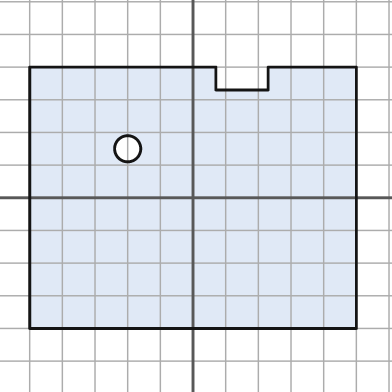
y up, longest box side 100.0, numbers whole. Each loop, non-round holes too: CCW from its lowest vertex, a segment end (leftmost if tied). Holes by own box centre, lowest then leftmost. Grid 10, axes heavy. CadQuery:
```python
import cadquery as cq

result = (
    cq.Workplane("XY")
    .moveTo(-50.0, -40.0)
    .lineTo(50.0, -40.0)
    .lineTo(50.0, 40.0)
    .lineTo(23.0, 40.0)
    .lineTo(23.0, 33.0)
    .lineTo(7.0, 33.0)
    .lineTo(7.0, 40.0)
    .lineTo(-50.0, 40.0)
    .close()
    .moveTo(-20.0, 15.0)
    .circle(4.0)
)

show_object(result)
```